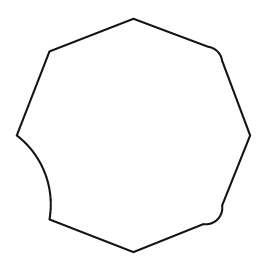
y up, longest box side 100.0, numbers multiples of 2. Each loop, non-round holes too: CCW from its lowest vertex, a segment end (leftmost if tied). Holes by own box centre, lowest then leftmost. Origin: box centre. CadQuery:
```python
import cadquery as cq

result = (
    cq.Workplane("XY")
    .moveTo(0.0, -50.0)
    .lineTo(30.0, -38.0)
    .threePointArc((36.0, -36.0), (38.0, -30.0))
    .lineTo(50.0, 0.0)
    .lineTo(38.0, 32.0)
    .threePointArc((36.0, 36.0), (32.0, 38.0))
    .lineTo(0.0, 50.0)
    .lineTo(-36.0, 36.0)
    .lineTo(-50.0, 0.0)
    .threePointArc((-38.0, -16.0), (-36.0, -36.0))
    .close()
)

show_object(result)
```